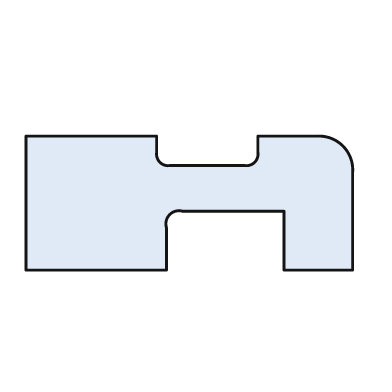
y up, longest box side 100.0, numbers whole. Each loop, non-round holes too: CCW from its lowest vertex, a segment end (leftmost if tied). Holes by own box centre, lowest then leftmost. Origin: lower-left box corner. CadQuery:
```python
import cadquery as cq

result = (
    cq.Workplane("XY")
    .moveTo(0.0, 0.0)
    .lineTo(43.0, 0.0)
    .lineTo(43.0, 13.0)
    .threePointArc((44.0, 17.0), (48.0, 18.0))
    .lineTo(79.0, 18.0)
    .lineTo(79.0, 0.0)
    .lineTo(100.0, 0.0)
    .lineTo(100.0, 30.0)
    .threePointArc((97.0, 38.0), (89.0, 41.0))
    .lineTo(71.0, 41.0)
    .lineTo(71.0, 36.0)
    .threePointArc((70.0, 33.0), (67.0, 32.0))
    .lineTo(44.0, 32.0)
    .threePointArc((41.0, 33.0), (40.0, 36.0))
    .lineTo(40.0, 41.0)
    .lineTo(0.0, 41.0)
    .close()
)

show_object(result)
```